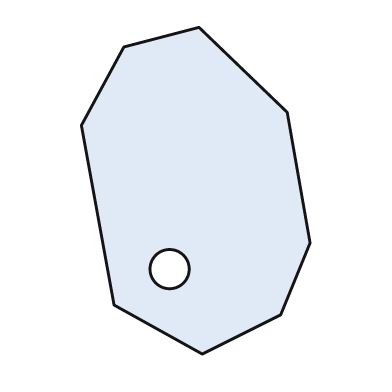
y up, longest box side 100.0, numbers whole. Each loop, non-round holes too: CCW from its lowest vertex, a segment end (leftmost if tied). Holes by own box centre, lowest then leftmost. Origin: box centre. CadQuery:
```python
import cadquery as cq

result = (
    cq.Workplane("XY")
    .moveTo(2.0, -50.0)
    .lineTo(26.0, -38.0)
    .lineTo(35.0, -16.0)
    .lineTo(28.0, 24.0)
    .lineTo(1.0, 50.0)
    .lineTo(-22.0, 44.0)
    .lineTo(-35.0, 20.0)
    .lineTo(-25.0, -35.0)
    .close()
    .moveTo(-8.0, -24.0)
    .circle(6.0)
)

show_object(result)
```